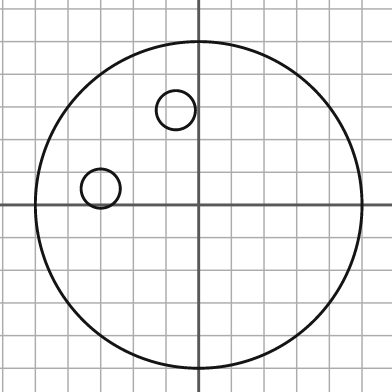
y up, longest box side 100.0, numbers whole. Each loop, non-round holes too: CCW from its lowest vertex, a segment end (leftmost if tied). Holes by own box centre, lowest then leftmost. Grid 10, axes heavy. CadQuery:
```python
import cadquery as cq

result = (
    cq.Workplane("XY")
    .moveTo(0.0, 0.0)
    .circle(50.0)
    .moveTo(-30.0, 5.0)
    .circle(6.0)
    .moveTo(-7.0, 29.0)
    .circle(6.0)
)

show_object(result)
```